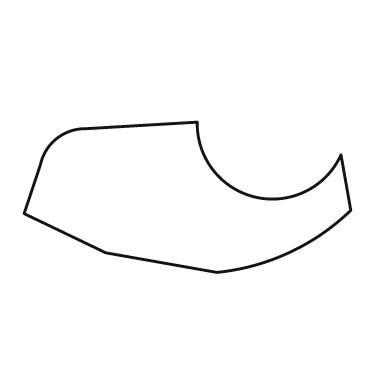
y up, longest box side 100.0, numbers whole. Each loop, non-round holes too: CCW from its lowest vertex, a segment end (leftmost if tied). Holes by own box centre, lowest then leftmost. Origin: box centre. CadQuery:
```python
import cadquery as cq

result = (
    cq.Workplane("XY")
    .moveTo(9.0, -23.0)
    .threePointArc((31.0, -17.0), (50.0, -4.0))
    .lineTo(47.0, 13.0)
    .threePointArc((21.0, 0.0), (3.0, 23.0))
    .lineTo(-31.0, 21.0)
    .threePointArc((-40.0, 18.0), (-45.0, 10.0))
    .lineTo(-50.0, -5.0)
    .lineTo(-25.0, -17.0)
    .close()
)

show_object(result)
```